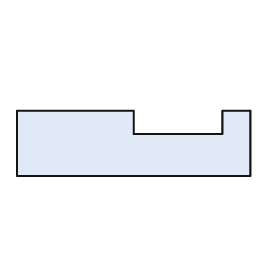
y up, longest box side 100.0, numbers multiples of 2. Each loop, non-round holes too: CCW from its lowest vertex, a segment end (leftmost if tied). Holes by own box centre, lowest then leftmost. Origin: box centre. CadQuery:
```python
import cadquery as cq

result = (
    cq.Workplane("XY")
    .moveTo(-50.0, -14.0)
    .lineTo(50.0, -14.0)
    .lineTo(50.0, 14.0)
    .lineTo(38.0, 14.0)
    .lineTo(38.0, 4.0)
    .lineTo(0.0, 4.0)
    .lineTo(0.0, 14.0)
    .lineTo(-50.0, 14.0)
    .close()
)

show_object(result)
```